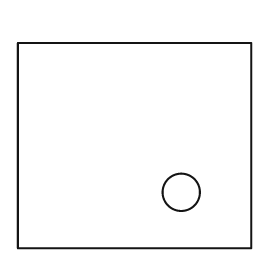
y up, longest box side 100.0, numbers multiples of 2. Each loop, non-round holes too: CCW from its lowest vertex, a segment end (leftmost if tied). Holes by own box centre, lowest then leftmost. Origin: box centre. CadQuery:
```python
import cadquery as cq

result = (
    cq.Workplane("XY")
    .moveTo(-50.0, -44.0)
    .lineTo(50.0, -44.0)
    .lineTo(50.0, 44.0)
    .lineTo(-50.0, 44.0)
    .close()
    .moveTo(20.0, -20.0)
    .circle(8.0)
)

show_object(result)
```